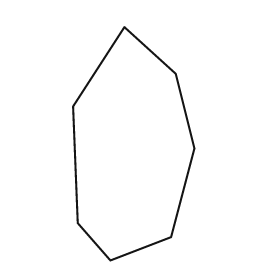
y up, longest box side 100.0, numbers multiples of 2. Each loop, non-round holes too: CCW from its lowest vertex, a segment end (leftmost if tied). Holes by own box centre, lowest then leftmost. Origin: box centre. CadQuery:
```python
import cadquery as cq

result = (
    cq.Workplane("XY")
    .moveTo(-10.0, -50.0)
    .lineTo(16.0, -40.0)
    .lineTo(26.0, -2.0)
    .lineTo(18.0, 30.0)
    .lineTo(-4.0, 50.0)
    .lineTo(-26.0, 16.0)
    .lineTo(-24.0, -34.0)
    .close()
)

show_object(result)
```